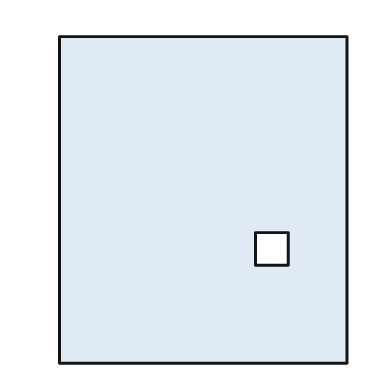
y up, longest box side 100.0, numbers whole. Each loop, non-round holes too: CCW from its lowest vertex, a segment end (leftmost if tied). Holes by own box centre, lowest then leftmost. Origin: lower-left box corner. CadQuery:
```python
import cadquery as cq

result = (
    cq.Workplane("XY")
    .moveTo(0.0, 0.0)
    .lineTo(88.0, 0.0)
    .lineTo(88.0, 100.0)
    .lineTo(0.0, 100.0)
    .close()
    .moveTo(60.0, 30.0)
    .lineTo(70.0, 30.0)
    .lineTo(70.0, 40.0)
    .lineTo(60.0, 40.0)
    .close()
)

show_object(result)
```